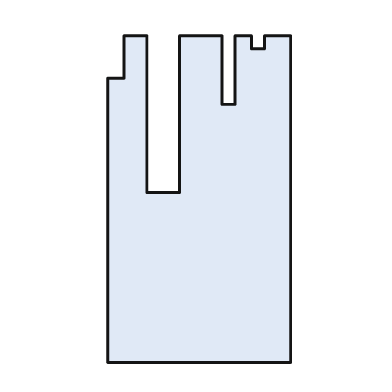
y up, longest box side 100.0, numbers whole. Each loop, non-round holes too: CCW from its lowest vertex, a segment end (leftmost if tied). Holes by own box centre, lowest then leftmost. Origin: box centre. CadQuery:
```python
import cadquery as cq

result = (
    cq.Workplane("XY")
    .moveTo(-28.0, -50.0)
    .lineTo(28.0, -50.0)
    .lineTo(28.0, 50.0)
    .lineTo(20.0, 50.0)
    .lineTo(20.0, 46.0)
    .lineTo(16.0, 46.0)
    .lineTo(16.0, 50.0)
    .lineTo(11.0, 50.0)
    .lineTo(11.0, 29.0)
    .lineTo(7.0, 29.0)
    .lineTo(7.0, 50.0)
    .lineTo(-6.0, 50.0)
    .lineTo(-6.0, 2.0)
    .lineTo(-16.0, 2.0)
    .lineTo(-16.0, 50.0)
    .lineTo(-23.0, 50.0)
    .lineTo(-23.0, 37.0)
    .lineTo(-28.0, 37.0)
    .close()
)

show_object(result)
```